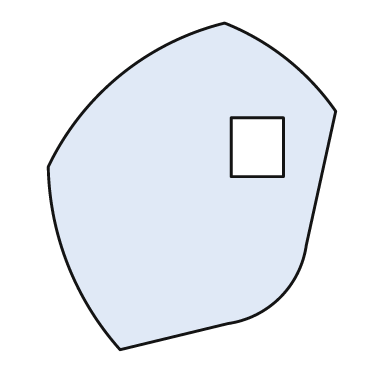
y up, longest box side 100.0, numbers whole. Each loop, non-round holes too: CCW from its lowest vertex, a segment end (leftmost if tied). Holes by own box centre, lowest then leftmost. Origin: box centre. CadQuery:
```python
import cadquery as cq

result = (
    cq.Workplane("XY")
    .moveTo(-22.0, -50.0)
    .lineTo(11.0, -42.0)
    .threePointArc((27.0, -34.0), (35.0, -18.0))
    .lineTo(44.0, 23.0)
    .threePointArc((29.0, 39.0), (10.0, 50.0))
    .threePointArc((-22.0, 34.0), (-44.0, 6.0))
    .threePointArc((-38.0, -24.0), (-22.0, -50.0))
    .close()
    .moveTo(12.0, 3.0)
    .lineTo(28.0, 3.0)
    .lineTo(28.0, 21.0)
    .lineTo(12.0, 21.0)
    .close()
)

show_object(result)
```